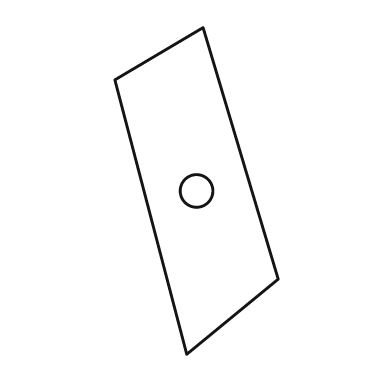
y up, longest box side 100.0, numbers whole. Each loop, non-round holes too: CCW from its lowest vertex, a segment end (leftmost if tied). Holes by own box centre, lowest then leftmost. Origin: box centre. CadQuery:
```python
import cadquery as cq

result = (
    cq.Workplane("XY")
    .moveTo(-3.0, -50.0)
    .lineTo(25.0, -27.0)
    .lineTo(2.0, 50.0)
    .lineTo(-25.0, 34.0)
    .close()
    .moveTo(0.0, 0.0)
    .circle(5.0)
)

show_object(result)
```